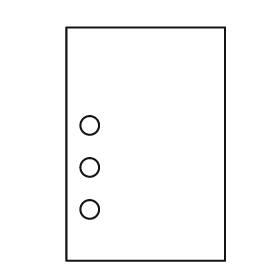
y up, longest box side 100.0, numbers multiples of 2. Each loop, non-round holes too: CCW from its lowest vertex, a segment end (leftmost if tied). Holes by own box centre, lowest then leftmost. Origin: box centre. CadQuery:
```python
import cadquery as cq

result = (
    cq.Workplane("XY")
    .moveTo(-34.0, -50.0)
    .lineTo(34.0, -50.0)
    .lineTo(34.0, 50.0)
    .lineTo(-34.0, 50.0)
    .close()
    .moveTo(-24.0, -28.0)
    .circle(4.0)
    .moveTo(-24.0, -10.0)
    .circle(4.0)
    .moveTo(-24.0, 8.0)
    .circle(4.0)
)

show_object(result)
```